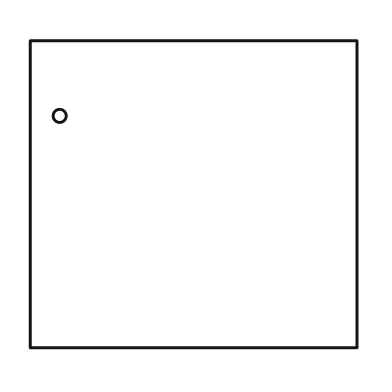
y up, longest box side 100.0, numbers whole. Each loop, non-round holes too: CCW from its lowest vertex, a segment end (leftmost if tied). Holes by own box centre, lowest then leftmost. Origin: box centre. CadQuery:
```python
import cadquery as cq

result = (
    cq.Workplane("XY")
    .moveTo(-50.0, -47.0)
    .lineTo(50.0, -47.0)
    .lineTo(50.0, 47.0)
    .lineTo(-50.0, 47.0)
    .close()
    .moveTo(-41.0, 24.0)
    .circle(2.0)
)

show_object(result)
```